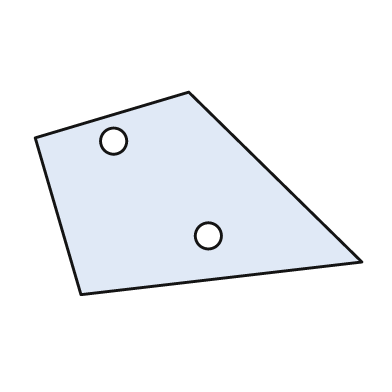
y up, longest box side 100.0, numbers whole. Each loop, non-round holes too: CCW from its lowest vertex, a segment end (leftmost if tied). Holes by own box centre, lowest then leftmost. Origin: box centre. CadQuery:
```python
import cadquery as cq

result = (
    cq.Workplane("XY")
    .moveTo(-36.0, -31.0)
    .lineTo(50.0, -21.0)
    .lineTo(-3.0, 31.0)
    .lineTo(-50.0, 17.0)
    .close()
    .moveTo(3.0, -13.0)
    .circle(4.0)
    .moveTo(-26.0, 16.0)
    .circle(4.0)
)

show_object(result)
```